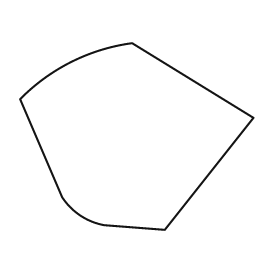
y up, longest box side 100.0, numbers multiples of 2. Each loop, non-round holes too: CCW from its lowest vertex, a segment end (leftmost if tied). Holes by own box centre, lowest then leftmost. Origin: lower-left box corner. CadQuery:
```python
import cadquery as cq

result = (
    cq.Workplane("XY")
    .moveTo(62.0, 0.0)
    .lineTo(100.0, 48.0)
    .lineTo(48.0, 80.0)
    .threePointArc((22.0, 72.0), (0.0, 56.0))
    .lineTo(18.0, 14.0)
    .threePointArc((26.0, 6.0), (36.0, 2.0))
    .close()
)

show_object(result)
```